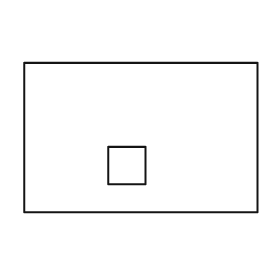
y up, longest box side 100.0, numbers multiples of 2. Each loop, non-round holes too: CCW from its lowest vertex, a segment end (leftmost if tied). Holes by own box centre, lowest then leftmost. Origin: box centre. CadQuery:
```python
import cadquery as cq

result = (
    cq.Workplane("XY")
    .moveTo(-50.0, -32.0)
    .lineTo(50.0, -32.0)
    .lineTo(50.0, 32.0)
    .lineTo(-50.0, 32.0)
    .close()
    .moveTo(-14.0, -20.0)
    .lineTo(2.0, -20.0)
    .lineTo(2.0, -4.0)
    .lineTo(-14.0, -4.0)
    .close()
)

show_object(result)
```